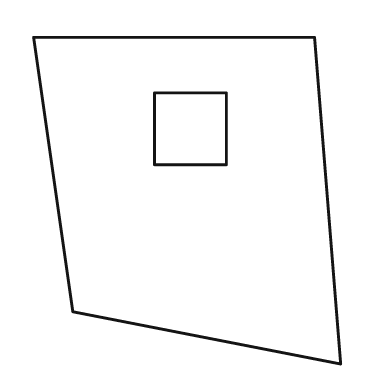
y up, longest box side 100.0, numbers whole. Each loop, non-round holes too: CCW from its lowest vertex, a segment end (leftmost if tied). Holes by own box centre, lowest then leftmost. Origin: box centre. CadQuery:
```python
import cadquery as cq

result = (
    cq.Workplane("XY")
    .moveTo(47.0, -50.0)
    .lineTo(39.0, 50.0)
    .lineTo(-47.0, 50.0)
    .lineTo(-35.0, -34.0)
    .close()
    .moveTo(-10.0, 11.0)
    .lineTo(12.0, 11.0)
    .lineTo(12.0, 33.0)
    .lineTo(-10.0, 33.0)
    .close()
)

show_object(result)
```